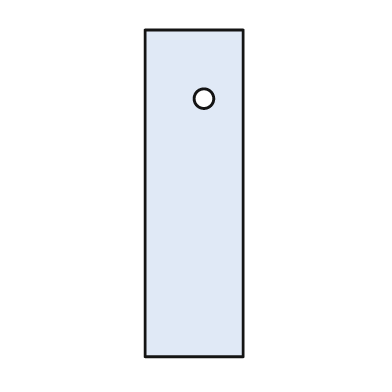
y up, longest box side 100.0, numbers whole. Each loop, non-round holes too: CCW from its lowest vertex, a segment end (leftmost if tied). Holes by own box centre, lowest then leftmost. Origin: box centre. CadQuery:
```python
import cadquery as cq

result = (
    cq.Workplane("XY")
    .moveTo(-15.0, -50.0)
    .lineTo(15.0, -50.0)
    .lineTo(15.0, 50.0)
    .lineTo(-15.0, 50.0)
    .close()
    .moveTo(3.0, 29.0)
    .circle(3.0)
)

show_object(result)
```